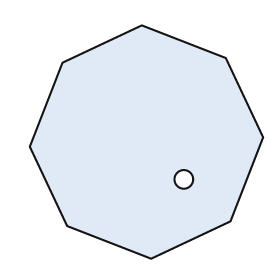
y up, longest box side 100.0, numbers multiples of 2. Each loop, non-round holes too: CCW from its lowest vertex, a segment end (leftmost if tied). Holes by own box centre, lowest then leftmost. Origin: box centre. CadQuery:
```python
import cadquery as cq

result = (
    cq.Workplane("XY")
    .moveTo(2.0, -50.0)
    .lineTo(36.0, -34.0)
    .lineTo(50.0, 2.0)
    .lineTo(34.0, 36.0)
    .lineTo(-2.0, 50.0)
    .lineTo(-36.0, 34.0)
    .lineTo(-50.0, -2.0)
    .lineTo(-34.0, -36.0)
    .close()
    .moveTo(16.0, -16.0)
    .circle(4.0)
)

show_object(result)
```